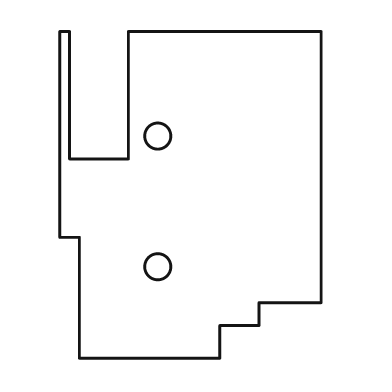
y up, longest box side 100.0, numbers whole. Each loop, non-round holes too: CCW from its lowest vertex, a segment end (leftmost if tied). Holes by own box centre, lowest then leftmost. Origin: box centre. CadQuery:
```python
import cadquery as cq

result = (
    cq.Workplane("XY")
    .moveTo(-34.0, -50.0)
    .lineTo(9.0, -50.0)
    .lineTo(9.0, -40.0)
    .lineTo(21.0, -40.0)
    .lineTo(21.0, -33.0)
    .lineTo(40.0, -33.0)
    .lineTo(40.0, 50.0)
    .lineTo(-19.0, 50.0)
    .lineTo(-19.0, 11.0)
    .lineTo(-37.0, 11.0)
    .lineTo(-37.0, 50.0)
    .lineTo(-40.0, 50.0)
    .lineTo(-40.0, -13.0)
    .lineTo(-34.0, -13.0)
    .close()
    .moveTo(-10.0, -22.0)
    .circle(4.0)
    .moveTo(-10.0, 18.0)
    .circle(4.0)
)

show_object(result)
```